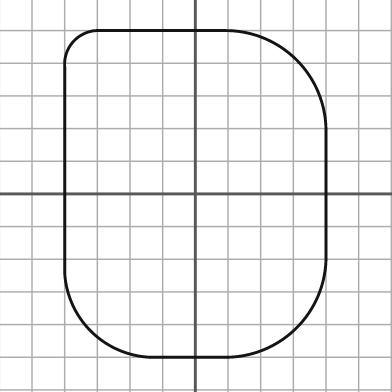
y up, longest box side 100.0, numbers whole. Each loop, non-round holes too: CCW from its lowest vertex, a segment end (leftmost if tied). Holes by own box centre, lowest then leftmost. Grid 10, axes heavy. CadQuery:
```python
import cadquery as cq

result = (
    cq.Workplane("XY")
    .moveTo(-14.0, -50.0)
    .lineTo(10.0, -50.0)
    .threePointArc((31.0, -41.0), (40.0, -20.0))
    .lineTo(40.0, 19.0)
    .threePointArc((31.0, 41.0), (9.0, 50.0))
    .lineTo(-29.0, 50.0)
    .threePointArc((-37.0, 47.0), (-40.0, 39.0))
    .lineTo(-40.0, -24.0)
    .threePointArc((-32.0, -42.0), (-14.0, -50.0))
    .close()
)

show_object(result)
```